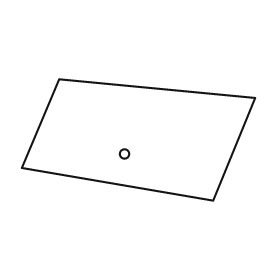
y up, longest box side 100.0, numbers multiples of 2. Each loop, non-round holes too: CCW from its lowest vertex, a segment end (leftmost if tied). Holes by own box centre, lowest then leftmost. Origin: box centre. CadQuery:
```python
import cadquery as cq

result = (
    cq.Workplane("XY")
    .moveTo(32.0, -26.0)
    .lineTo(50.0, 18.0)
    .lineTo(-34.0, 26.0)
    .lineTo(-50.0, -12.0)
    .close()
    .moveTo(-6.0, -6.0)
    .circle(2.0)
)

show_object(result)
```